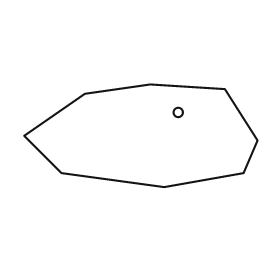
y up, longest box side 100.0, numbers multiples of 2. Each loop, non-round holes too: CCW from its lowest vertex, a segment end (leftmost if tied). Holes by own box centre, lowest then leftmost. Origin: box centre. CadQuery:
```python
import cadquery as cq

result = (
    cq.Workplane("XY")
    .moveTo(10.0, -22.0)
    .lineTo(44.0, -16.0)
    .lineTo(50.0, -2.0)
    .lineTo(36.0, 20.0)
    .lineTo(4.0, 22.0)
    .lineTo(-24.0, 18.0)
    .lineTo(-50.0, 0.0)
    .lineTo(-34.0, -16.0)
    .close()
    .moveTo(16.0, 10.0)
    .circle(2.0)
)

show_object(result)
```